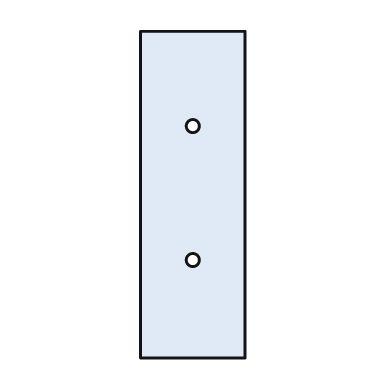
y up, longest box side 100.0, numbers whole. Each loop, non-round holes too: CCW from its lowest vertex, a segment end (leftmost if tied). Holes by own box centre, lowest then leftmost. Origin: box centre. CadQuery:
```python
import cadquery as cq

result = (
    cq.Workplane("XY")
    .moveTo(-16.0, -50.0)
    .lineTo(16.0, -50.0)
    .lineTo(16.0, 50.0)
    .lineTo(-16.0, 50.0)
    .close()
    .moveTo(0.0, -20.0)
    .circle(2.0)
    .moveTo(0.0, 21.0)
    .circle(2.0)
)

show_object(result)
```